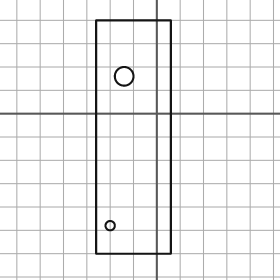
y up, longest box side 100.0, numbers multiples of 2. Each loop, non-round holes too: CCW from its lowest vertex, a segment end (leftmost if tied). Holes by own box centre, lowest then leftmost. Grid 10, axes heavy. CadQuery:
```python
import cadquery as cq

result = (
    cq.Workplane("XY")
    .moveTo(-26.0, -60.0)
    .lineTo(6.0, -60.0)
    .lineTo(6.0, 40.0)
    .lineTo(-26.0, 40.0)
    .close()
    .moveTo(-20.0, -48.0)
    .circle(2.0)
    .moveTo(-14.0, 16.0)
    .circle(4.0)
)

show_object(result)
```